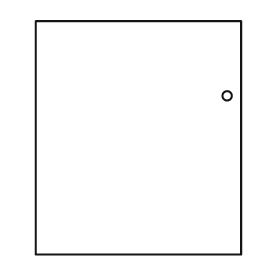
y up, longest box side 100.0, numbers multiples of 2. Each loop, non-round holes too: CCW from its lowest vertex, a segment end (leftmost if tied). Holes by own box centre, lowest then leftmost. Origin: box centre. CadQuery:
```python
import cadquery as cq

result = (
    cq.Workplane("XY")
    .moveTo(-44.0, -50.0)
    .lineTo(44.0, -50.0)
    .lineTo(44.0, 50.0)
    .lineTo(-44.0, 50.0)
    .close()
    .moveTo(38.0, 18.0)
    .circle(2.0)
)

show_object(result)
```